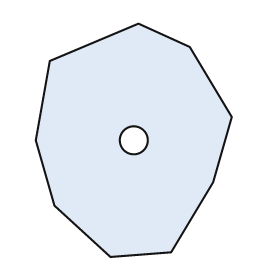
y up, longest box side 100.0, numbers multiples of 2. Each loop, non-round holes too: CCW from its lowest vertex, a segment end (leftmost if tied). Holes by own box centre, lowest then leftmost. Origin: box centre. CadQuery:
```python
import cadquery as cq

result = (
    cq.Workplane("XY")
    .moveTo(-10.0, -50.0)
    .lineTo(16.0, -48.0)
    .lineTo(34.0, -18.0)
    .lineTo(42.0, 10.0)
    .lineTo(24.0, 40.0)
    .lineTo(2.0, 50.0)
    .lineTo(-36.0, 34.0)
    .lineTo(-42.0, 0.0)
    .lineTo(-34.0, -28.0)
    .close()
    .moveTo(0.0, 0.0)
    .circle(6.0)
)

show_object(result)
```